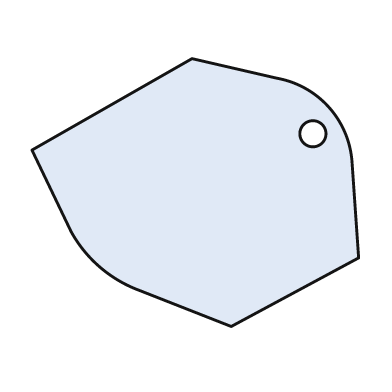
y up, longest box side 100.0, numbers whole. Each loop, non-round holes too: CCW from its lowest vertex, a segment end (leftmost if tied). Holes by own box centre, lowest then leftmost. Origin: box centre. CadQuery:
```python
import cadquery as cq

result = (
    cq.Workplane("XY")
    .moveTo(11.0, -41.0)
    .lineTo(50.0, -20.0)
    .lineTo(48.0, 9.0)
    .threePointArc((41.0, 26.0), (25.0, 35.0))
    .lineTo(-1.0, 41.0)
    .lineTo(-50.0, 13.0)
    .lineTo(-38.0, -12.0)
    .threePointArc((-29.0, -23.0), (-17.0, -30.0))
    .close()
    .moveTo(36.0, 18.0)
    .circle(4.0)
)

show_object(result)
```